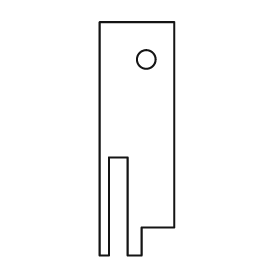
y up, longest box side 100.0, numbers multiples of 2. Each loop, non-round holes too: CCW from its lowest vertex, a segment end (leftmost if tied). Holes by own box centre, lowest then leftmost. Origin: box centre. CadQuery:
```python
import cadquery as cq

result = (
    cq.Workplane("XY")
    .moveTo(-16.0, -50.0)
    .lineTo(-12.0, -50.0)
    .lineTo(-12.0, -8.0)
    .lineTo(-4.0, -8.0)
    .lineTo(-4.0, -50.0)
    .lineTo(2.0, -50.0)
    .lineTo(2.0, -38.0)
    .lineTo(16.0, -38.0)
    .lineTo(16.0, 50.0)
    .lineTo(-16.0, 50.0)
    .close()
    .moveTo(4.0, 34.0)
    .circle(4.0)
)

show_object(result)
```